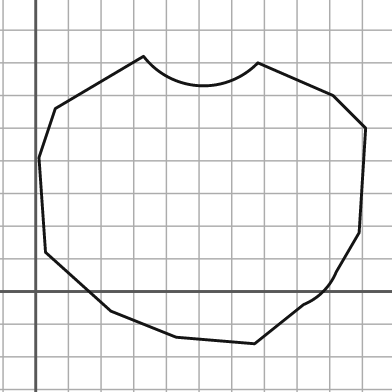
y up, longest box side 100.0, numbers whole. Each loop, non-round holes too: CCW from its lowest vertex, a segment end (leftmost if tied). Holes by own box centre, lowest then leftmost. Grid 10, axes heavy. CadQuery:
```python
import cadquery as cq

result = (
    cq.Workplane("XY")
    .moveTo(67.0, -16.0)
    .lineTo(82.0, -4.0)
    .threePointArc((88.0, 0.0), (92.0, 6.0))
    .lineTo(99.0, 18.0)
    .lineTo(101.0, 50.0)
    .lineTo(91.0, 60.0)
    .lineTo(68.0, 70.0)
    .threePointArc((50.0, 63.0), (33.0, 72.0))
    .lineTo(6.0, 56.0)
    .lineTo(1.0, 41.0)
    .lineTo(3.0, 12.0)
    .lineTo(23.0, -6.0)
    .lineTo(43.0, -14.0)
    .close()
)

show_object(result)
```